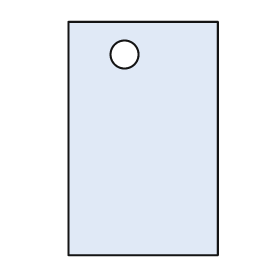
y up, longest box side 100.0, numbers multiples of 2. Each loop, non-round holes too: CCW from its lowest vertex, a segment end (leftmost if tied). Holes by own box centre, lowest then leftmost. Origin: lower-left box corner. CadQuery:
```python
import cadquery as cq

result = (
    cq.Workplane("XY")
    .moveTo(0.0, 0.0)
    .lineTo(64.0, 0.0)
    .lineTo(64.0, 100.0)
    .lineTo(0.0, 100.0)
    .close()
    .moveTo(24.0, 86.0)
    .circle(6.0)
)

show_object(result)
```